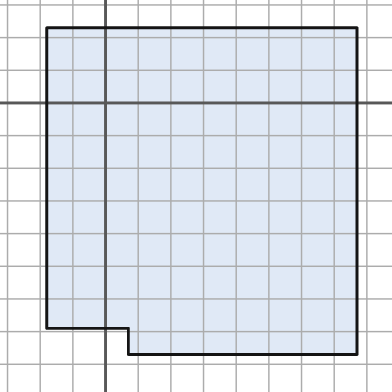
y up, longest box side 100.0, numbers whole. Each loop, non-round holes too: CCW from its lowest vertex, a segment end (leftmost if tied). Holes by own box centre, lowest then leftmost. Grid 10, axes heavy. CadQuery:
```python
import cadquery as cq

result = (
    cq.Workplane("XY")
    .moveTo(7.0, -77.0)
    .lineTo(77.0, -77.0)
    .lineTo(77.0, 23.0)
    .lineTo(-18.0, 23.0)
    .lineTo(-18.0, -69.0)
    .lineTo(7.0, -69.0)
    .close()
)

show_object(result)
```